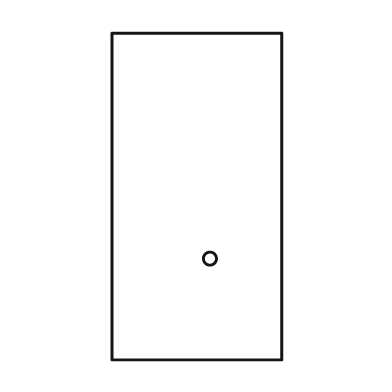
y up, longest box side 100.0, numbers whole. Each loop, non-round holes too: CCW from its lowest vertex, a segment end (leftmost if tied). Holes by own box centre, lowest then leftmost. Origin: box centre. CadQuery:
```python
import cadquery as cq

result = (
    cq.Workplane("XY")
    .moveTo(-26.0, -50.0)
    .lineTo(26.0, -50.0)
    .lineTo(26.0, 50.0)
    .lineTo(-26.0, 50.0)
    .close()
    .moveTo(4.0, -19.0)
    .circle(2.0)
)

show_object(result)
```